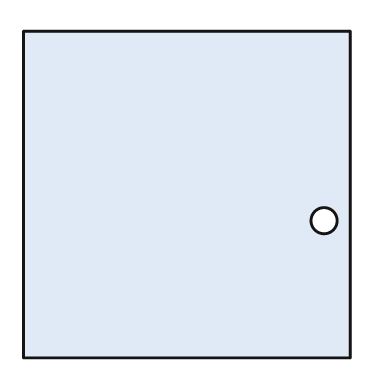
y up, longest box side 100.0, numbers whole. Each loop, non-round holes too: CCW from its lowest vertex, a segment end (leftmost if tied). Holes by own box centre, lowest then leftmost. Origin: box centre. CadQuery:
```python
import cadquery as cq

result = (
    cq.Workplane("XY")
    .moveTo(-50.0, -50.0)
    .lineTo(50.0, -50.0)
    .lineTo(50.0, 50.0)
    .lineTo(-50.0, 50.0)
    .close()
    .moveTo(42.0, -8.0)
    .circle(4.0)
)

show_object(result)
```